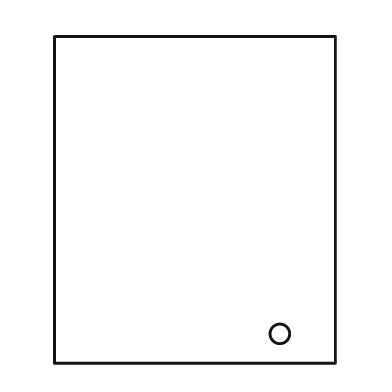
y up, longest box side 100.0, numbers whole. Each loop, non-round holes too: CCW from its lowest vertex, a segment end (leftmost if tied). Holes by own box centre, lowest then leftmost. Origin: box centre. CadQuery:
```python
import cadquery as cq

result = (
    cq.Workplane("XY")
    .moveTo(-43.0, -50.0)
    .lineTo(43.0, -50.0)
    .lineTo(43.0, 50.0)
    .lineTo(-43.0, 50.0)
    .close()
    .moveTo(26.0, -41.0)
    .circle(3.0)
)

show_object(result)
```